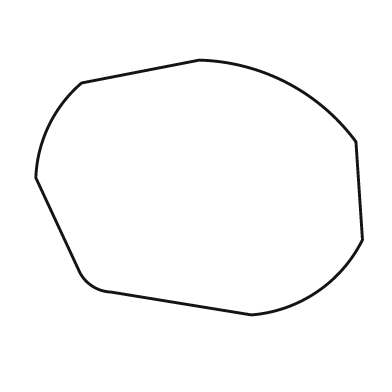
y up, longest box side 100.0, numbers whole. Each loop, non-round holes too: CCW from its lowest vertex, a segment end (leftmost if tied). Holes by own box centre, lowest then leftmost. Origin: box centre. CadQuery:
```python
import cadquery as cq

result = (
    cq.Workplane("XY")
    .moveTo(16.0, -39.0)
    .threePointArc((36.0, -32.0), (50.0, -16.0))
    .lineTo(48.0, 14.0)
    .threePointArc((27.0, 32.0), (0.0, 39.0))
    .lineTo(-36.0, 32.0)
    .threePointArc((-46.0, 19.0), (-50.0, 3.0))
    .lineTo(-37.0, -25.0)
    .threePointArc((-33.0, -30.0), (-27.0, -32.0))
    .close()
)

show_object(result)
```